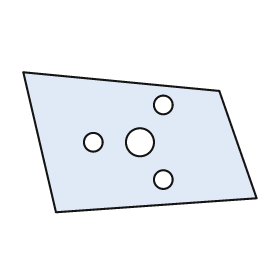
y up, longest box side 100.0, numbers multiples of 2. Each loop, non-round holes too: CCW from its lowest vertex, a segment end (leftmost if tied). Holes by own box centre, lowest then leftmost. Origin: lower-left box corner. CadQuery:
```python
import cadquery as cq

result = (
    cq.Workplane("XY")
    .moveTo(14.0, 0.0)
    .lineTo(100.0, 6.0)
    .lineTo(84.0, 52.0)
    .lineTo(0.0, 60.0)
    .close()
    .moveTo(60.0, 14.0)
    .circle(4.0)
    .moveTo(30.0, 30.0)
    .circle(4.0)
    .moveTo(50.0, 30.0)
    .circle(6.0)
    .moveTo(60.0, 46.0)
    .circle(4.0)
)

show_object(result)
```